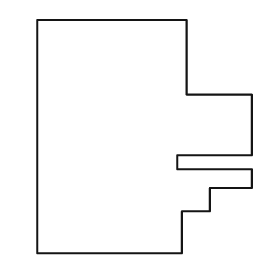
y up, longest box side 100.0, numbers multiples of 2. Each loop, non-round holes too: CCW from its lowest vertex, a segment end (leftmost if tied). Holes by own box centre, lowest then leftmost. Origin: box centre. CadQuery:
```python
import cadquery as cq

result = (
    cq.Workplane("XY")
    .moveTo(-46.0, -50.0)
    .lineTo(16.0, -50.0)
    .lineTo(16.0, -32.0)
    .lineTo(28.0, -32.0)
    .lineTo(28.0, -22.0)
    .lineTo(46.0, -22.0)
    .lineTo(46.0, -14.0)
    .lineTo(14.0, -14.0)
    .lineTo(14.0, -8.0)
    .lineTo(46.0, -8.0)
    .lineTo(46.0, 18.0)
    .lineTo(18.0, 18.0)
    .lineTo(18.0, 50.0)
    .lineTo(-46.0, 50.0)
    .close()
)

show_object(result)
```